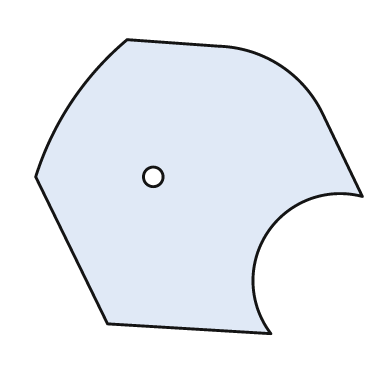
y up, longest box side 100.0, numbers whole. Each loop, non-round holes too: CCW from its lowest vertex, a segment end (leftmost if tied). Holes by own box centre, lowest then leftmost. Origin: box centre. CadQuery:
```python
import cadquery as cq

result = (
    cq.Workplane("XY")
    .moveTo(22.0, -45.0)
    .threePointArc((21.0, -14.0), (50.0, -3.0))
    .lineTo(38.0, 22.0)
    .threePointArc((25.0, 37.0), (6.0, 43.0))
    .lineTo(-22.0, 45.0)
    .threePointArc((-39.0, 26.0), (-50.0, 3.0))
    .lineTo(-28.0, -42.0)
    .close()
    .moveTo(-14.0, 3.0)
    .circle(3.0)
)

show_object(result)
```